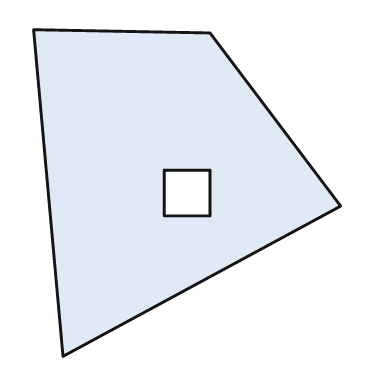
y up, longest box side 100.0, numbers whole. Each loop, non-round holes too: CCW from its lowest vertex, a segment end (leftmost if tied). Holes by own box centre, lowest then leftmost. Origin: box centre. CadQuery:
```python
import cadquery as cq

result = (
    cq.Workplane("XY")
    .moveTo(-38.0, -50.0)
    .lineTo(47.0, -4.0)
    .lineTo(7.0, 49.0)
    .lineTo(-47.0, 50.0)
    .close()
    .moveTo(-7.0, -7.0)
    .lineTo(7.0, -7.0)
    .lineTo(7.0, 7.0)
    .lineTo(-7.0, 7.0)
    .close()
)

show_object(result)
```